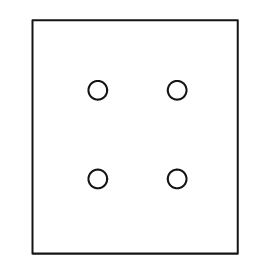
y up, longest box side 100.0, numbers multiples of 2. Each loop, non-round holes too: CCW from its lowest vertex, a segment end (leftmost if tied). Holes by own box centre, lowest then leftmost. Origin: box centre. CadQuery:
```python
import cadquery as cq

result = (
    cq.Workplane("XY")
    .moveTo(-44.0, -50.0)
    .lineTo(44.0, -50.0)
    .lineTo(44.0, 50.0)
    .lineTo(-44.0, 50.0)
    .close()
    .moveTo(-16.0, -18.0)
    .circle(4.0)
    .moveTo(18.0, -18.0)
    .circle(4.0)
    .moveTo(-16.0, 20.0)
    .circle(4.0)
    .moveTo(18.0, 20.0)
    .circle(4.0)
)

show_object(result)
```